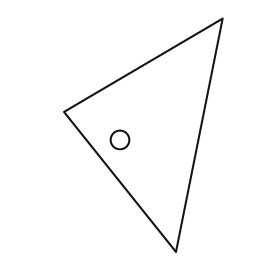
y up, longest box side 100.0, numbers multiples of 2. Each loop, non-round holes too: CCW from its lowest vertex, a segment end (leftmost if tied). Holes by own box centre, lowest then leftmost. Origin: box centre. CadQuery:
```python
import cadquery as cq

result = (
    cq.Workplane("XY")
    .moveTo(14.0, -50.0)
    .lineTo(34.0, 50.0)
    .lineTo(-34.0, 10.0)
    .close()
    .moveTo(-10.0, -2.0)
    .circle(4.0)
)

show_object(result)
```